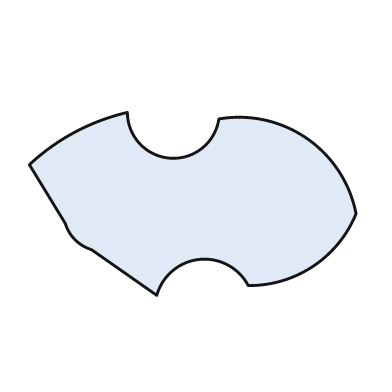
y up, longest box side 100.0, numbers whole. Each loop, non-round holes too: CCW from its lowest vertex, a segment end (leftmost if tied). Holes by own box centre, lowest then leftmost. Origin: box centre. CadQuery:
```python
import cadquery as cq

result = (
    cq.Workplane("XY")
    .moveTo(-11.0, -28.0)
    .threePointArc((2.0, -17.0), (17.0, -25.0))
    .threePointArc((37.0, -19.0), (50.0, -3.0))
    .threePointArc((35.0, 20.0), (8.0, 26.0))
    .threePointArc((-7.0, 14.0), (-20.0, 28.0))
    .threePointArc((-36.0, 22.0), (-50.0, 12.0))
    .lineTo(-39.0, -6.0)
    .threePointArc((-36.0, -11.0), (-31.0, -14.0))
    .close()
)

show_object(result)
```